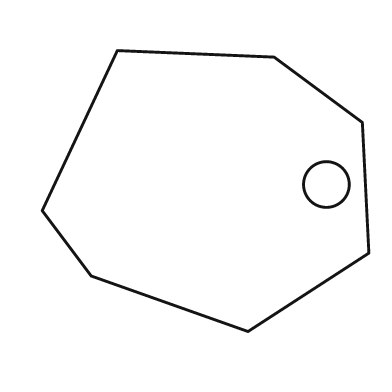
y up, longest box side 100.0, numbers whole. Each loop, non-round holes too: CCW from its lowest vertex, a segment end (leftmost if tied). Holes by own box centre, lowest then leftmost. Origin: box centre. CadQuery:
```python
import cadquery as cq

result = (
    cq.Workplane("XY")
    .moveTo(13.0, -43.0)
    .lineTo(50.0, -19.0)
    .lineTo(48.0, 21.0)
    .lineTo(21.0, 41.0)
    .lineTo(-27.0, 43.0)
    .lineTo(-50.0, -6.0)
    .lineTo(-35.0, -26.0)
    .close()
    .moveTo(37.0, 2.0)
    .circle(7.0)
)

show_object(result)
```